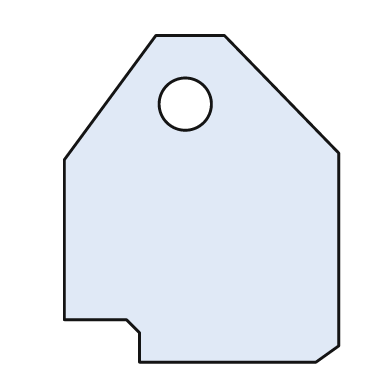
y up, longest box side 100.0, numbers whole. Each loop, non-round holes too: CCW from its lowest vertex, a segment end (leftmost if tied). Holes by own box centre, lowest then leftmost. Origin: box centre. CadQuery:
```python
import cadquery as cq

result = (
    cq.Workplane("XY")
    .moveTo(-19.0, -50.0)
    .lineTo(35.0, -50.0)
    .lineTo(42.0, -45.0)
    .lineTo(42.0, 14.0)
    .lineTo(7.0, 50.0)
    .lineTo(-14.0, 50.0)
    .lineTo(-42.0, 12.0)
    .lineTo(-42.0, -37.0)
    .lineTo(-23.0, -37.0)
    .lineTo(-19.0, -41.0)
    .close()
    .moveTo(-5.0, 29.0)
    .circle(8.0)
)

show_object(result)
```